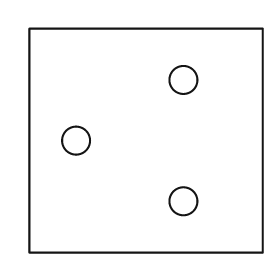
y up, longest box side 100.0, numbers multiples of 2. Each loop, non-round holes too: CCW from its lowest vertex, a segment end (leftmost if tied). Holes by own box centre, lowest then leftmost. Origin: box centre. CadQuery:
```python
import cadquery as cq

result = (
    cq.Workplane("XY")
    .moveTo(-50.0, -48.0)
    .lineTo(50.0, -48.0)
    .lineTo(50.0, 48.0)
    .lineTo(-50.0, 48.0)
    .close()
    .moveTo(16.0, -26.0)
    .circle(6.0)
    .moveTo(-30.0, 0.0)
    .circle(6.0)
    .moveTo(16.0, 26.0)
    .circle(6.0)
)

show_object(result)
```